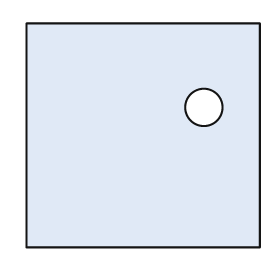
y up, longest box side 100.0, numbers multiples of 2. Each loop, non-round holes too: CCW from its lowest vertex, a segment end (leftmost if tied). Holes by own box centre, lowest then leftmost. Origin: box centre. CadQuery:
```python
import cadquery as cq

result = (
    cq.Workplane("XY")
    .moveTo(-50.0, -48.0)
    .lineTo(50.0, -48.0)
    .lineTo(50.0, 48.0)
    .lineTo(-50.0, 48.0)
    .close()
    .moveTo(26.0, 12.0)
    .circle(8.0)
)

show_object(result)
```